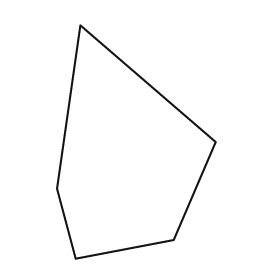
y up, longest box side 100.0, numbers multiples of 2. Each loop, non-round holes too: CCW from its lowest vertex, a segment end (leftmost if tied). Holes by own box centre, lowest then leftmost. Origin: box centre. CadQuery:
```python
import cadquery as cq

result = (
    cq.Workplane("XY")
    .moveTo(-26.0, -50.0)
    .lineTo(16.0, -42.0)
    .lineTo(34.0, 0.0)
    .lineTo(-24.0, 50.0)
    .lineTo(-34.0, -20.0)
    .close()
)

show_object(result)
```